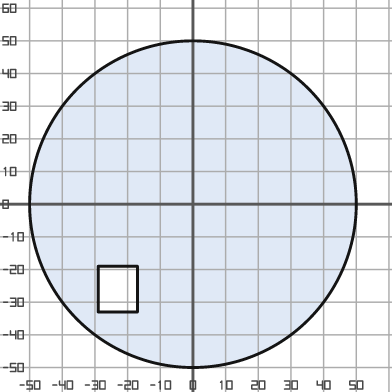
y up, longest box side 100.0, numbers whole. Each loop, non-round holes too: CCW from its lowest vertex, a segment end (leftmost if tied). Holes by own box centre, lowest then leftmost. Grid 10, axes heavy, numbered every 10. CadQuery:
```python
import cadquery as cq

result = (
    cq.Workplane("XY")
    .moveTo(0.0, 0.0)
    .circle(50.0)
    .moveTo(-29.0, -33.0)
    .lineTo(-17.0, -33.0)
    .lineTo(-17.0, -19.0)
    .lineTo(-29.0, -19.0)
    .close()
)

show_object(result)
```